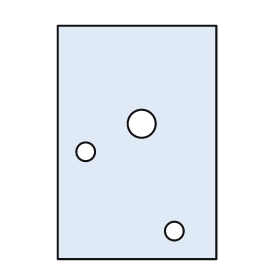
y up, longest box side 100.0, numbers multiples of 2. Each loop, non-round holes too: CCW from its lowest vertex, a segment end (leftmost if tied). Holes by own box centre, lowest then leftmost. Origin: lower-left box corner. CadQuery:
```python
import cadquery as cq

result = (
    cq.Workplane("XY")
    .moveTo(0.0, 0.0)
    .lineTo(68.0, 0.0)
    .lineTo(68.0, 100.0)
    .lineTo(0.0, 100.0)
    .close()
    .moveTo(50.0, 12.0)
    .circle(4.0)
    .moveTo(12.0, 46.0)
    .circle(4.0)
    .moveTo(36.0, 58.0)
    .circle(6.0)
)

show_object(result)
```